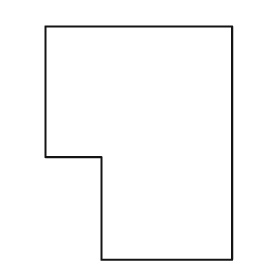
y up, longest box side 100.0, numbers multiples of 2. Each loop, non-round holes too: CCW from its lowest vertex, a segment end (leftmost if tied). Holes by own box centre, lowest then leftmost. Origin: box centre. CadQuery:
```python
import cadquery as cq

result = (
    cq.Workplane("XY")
    .moveTo(-16.0, -50.0)
    .lineTo(40.0, -50.0)
    .lineTo(40.0, 50.0)
    .lineTo(-40.0, 50.0)
    .lineTo(-40.0, -6.0)
    .lineTo(-16.0, -6.0)
    .close()
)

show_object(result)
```